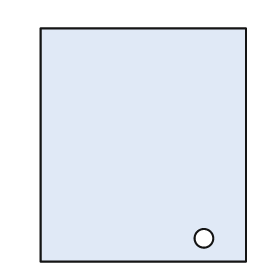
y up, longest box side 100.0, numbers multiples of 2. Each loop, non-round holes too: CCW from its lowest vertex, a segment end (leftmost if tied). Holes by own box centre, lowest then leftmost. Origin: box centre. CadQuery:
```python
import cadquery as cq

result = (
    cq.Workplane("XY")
    .moveTo(-44.0, -50.0)
    .lineTo(44.0, -50.0)
    .lineTo(44.0, 50.0)
    .lineTo(-44.0, 50.0)
    .close()
    .moveTo(26.0, -40.0)
    .circle(4.0)
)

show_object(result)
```